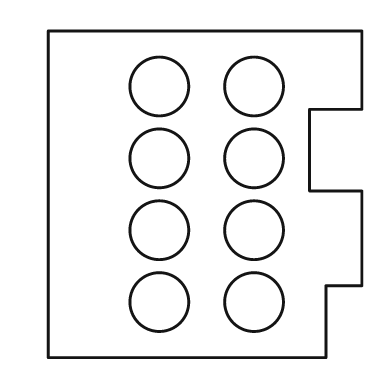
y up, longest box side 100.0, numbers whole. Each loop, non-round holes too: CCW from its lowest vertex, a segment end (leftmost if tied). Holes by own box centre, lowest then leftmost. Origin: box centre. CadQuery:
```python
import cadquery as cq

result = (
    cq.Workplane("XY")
    .moveTo(-48.0, -50.0)
    .lineTo(37.0, -50.0)
    .lineTo(37.0, -28.0)
    .lineTo(48.0, -28.0)
    .lineTo(48.0, 1.0)
    .lineTo(32.0, 1.0)
    .lineTo(32.0, 26.0)
    .lineTo(48.0, 26.0)
    .lineTo(48.0, 50.0)
    .lineTo(-48.0, 50.0)
    .close()
    .moveTo(-14.0, -33.0)
    .circle(9.0)
    .moveTo(15.0, -33.0)
    .circle(9.0)
    .moveTo(-14.0, -11.0)
    .circle(9.0)
    .moveTo(15.0, -11.0)
    .circle(9.0)
    .moveTo(-14.0, 11.0)
    .circle(9.0)
    .moveTo(15.0, 11.0)
    .circle(9.0)
    .moveTo(-14.0, 33.0)
    .circle(9.0)
    .moveTo(15.0, 33.0)
    .circle(9.0)
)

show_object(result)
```